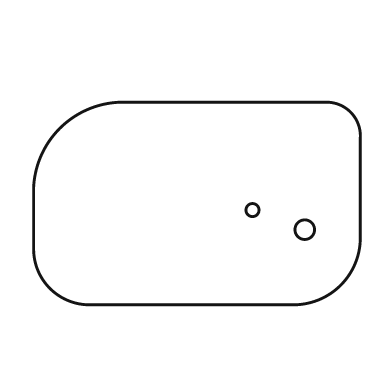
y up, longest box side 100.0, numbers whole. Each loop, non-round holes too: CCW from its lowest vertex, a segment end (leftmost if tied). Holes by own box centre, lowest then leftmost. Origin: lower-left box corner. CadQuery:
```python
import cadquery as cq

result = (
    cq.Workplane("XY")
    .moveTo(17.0, 0.0)
    .lineTo(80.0, 0.0)
    .threePointArc((94.0, 6.0), (100.0, 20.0))
    .lineTo(100.0, 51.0)
    .threePointArc((97.0, 59.0), (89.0, 62.0))
    .lineTo(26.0, 62.0)
    .threePointArc((8.0, 54.0), (0.0, 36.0))
    .lineTo(0.0, 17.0)
    .threePointArc((5.0, 5.0), (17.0, 0.0))
    .close()
    .moveTo(83.0, 23.0)
    .circle(3.0)
    .moveTo(67.0, 29.0)
    .circle(2.0)
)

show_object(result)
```